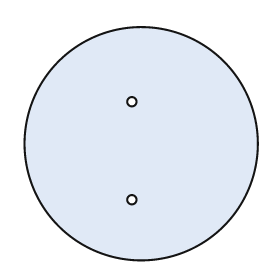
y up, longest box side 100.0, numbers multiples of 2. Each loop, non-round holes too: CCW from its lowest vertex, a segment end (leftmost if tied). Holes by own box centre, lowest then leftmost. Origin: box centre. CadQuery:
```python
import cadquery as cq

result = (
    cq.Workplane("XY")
    .moveTo(0.0, 0.0)
    .circle(50.0)
    .moveTo(-4.0, -24.0)
    .circle(2.0)
    .moveTo(-4.0, 18.0)
    .circle(2.0)
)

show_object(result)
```